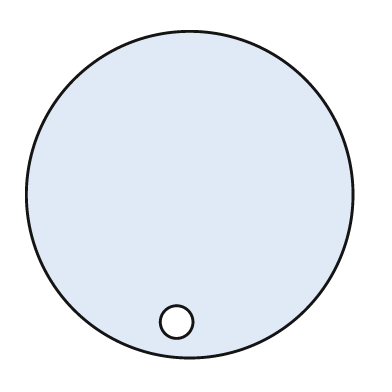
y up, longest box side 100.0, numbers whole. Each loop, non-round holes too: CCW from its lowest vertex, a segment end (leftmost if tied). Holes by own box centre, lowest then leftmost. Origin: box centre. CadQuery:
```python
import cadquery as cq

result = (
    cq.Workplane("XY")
    .moveTo(0.0, 0.0)
    .circle(50.0)
    .moveTo(-4.0, -39.0)
    .circle(5.0)
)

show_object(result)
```